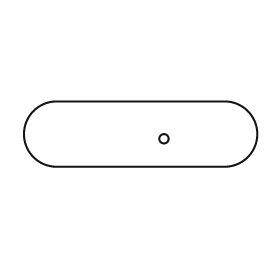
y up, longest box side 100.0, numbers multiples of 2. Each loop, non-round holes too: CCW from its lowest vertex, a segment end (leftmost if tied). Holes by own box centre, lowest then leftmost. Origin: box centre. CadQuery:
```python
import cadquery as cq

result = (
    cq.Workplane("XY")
    .moveTo(-36.0, -14.0)
    .lineTo(36.0, -14.0)
    .threePointArc((50.0, 0.0), (36.0, 14.0))
    .lineTo(-36.0, 14.0)
    .threePointArc((-50.0, 0.0), (-36.0, -14.0))
    .close()
    .moveTo(10.0, -2.0)
    .circle(2.0)
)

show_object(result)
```